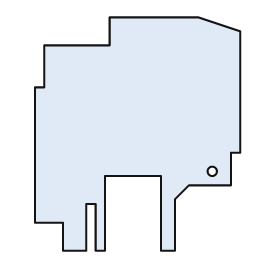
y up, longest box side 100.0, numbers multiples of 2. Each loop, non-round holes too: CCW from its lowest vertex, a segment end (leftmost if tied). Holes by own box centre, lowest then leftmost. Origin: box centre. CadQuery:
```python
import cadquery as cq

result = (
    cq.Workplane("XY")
    .moveTo(-32.0, -50.0)
    .lineTo(-22.0, -50.0)
    .lineTo(-22.0, -30.0)
    .lineTo(-18.0, -30.0)
    .lineTo(-18.0, -50.0)
    .lineTo(-14.0, -50.0)
    .lineTo(-14.0, -18.0)
    .lineTo(10.0, -18.0)
    .lineTo(10.0, -50.0)
    .lineTo(16.0, -50.0)
    .lineTo(16.0, -28.0)
    .lineTo(22.0, -22.0)
    .lineTo(40.0, -22.0)
    .lineTo(40.0, -8.0)
    .lineTo(44.0, -8.0)
    .lineTo(44.0, 44.0)
    .lineTo(26.0, 50.0)
    .lineTo(-12.0, 50.0)
    .lineTo(-12.0, 38.0)
    .lineTo(-40.0, 38.0)
    .lineTo(-40.0, 20.0)
    .lineTo(-44.0, 20.0)
    .lineTo(-44.0, -38.0)
    .lineTo(-32.0, -38.0)
    .close()
    .moveTo(32.0, -16.0)
    .circle(2.0)
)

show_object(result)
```